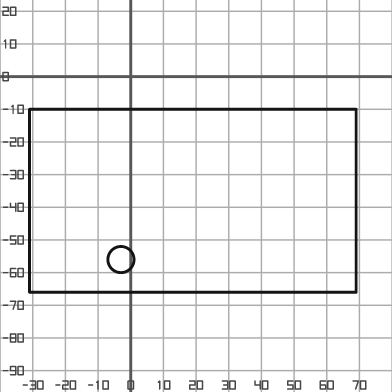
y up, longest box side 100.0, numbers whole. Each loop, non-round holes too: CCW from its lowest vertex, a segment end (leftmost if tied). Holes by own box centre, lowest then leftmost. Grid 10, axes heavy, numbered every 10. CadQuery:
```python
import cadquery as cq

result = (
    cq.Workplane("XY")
    .moveTo(-31.0, -66.0)
    .lineTo(69.0, -66.0)
    .lineTo(69.0, -10.0)
    .lineTo(-31.0, -10.0)
    .close()
    .moveTo(-3.0, -56.0)
    .circle(4.0)
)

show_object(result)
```